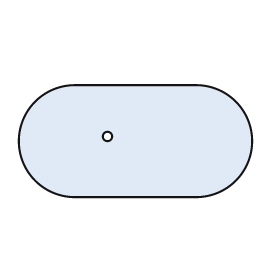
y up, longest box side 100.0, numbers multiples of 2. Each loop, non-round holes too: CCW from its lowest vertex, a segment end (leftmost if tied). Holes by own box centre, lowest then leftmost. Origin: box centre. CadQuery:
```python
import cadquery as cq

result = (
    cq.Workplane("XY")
    .moveTo(-26.0, -24.0)
    .lineTo(26.0, -24.0)
    .threePointArc((50.0, 0.0), (26.0, 24.0))
    .lineTo(-26.0, 24.0)
    .threePointArc((-50.0, 0.0), (-26.0, -24.0))
    .close()
    .moveTo(-12.0, 2.0)
    .circle(2.0)
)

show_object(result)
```